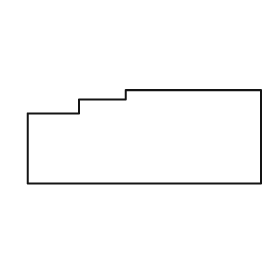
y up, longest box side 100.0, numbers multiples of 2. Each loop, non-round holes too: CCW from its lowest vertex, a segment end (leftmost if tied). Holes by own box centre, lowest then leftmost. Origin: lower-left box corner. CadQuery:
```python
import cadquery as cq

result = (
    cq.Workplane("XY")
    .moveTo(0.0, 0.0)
    .lineTo(100.0, 0.0)
    .lineTo(100.0, 40.0)
    .lineTo(42.0, 40.0)
    .lineTo(42.0, 36.0)
    .lineTo(22.0, 36.0)
    .lineTo(22.0, 30.0)
    .lineTo(0.0, 30.0)
    .close()
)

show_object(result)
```